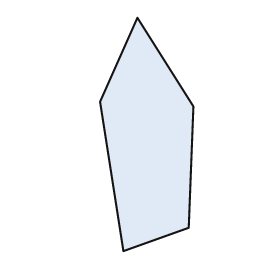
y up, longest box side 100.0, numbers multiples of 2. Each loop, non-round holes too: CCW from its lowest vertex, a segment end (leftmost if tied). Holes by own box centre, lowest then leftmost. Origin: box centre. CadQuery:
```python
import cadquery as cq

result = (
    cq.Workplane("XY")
    .moveTo(-10.0, -50.0)
    .lineTo(18.0, -40.0)
    .lineTo(20.0, 12.0)
    .lineTo(-4.0, 50.0)
    .lineTo(-20.0, 14.0)
    .close()
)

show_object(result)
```